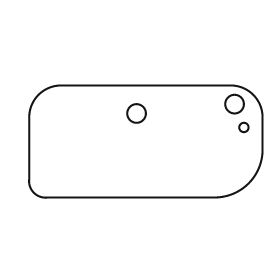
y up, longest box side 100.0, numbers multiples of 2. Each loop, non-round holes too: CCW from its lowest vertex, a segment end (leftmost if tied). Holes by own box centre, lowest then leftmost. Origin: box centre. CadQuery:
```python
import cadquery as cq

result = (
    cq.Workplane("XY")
    .moveTo(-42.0, -24.0)
    .lineTo(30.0, -24.0)
    .threePointArc((44.0, -18.0), (50.0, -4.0))
    .lineTo(50.0, 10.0)
    .threePointArc((46.0, 20.0), (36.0, 24.0))
    .lineTo(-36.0, 24.0)
    .threePointArc((-46.0, 20.0), (-50.0, 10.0))
    .lineTo(-50.0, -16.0)
    .threePointArc((-48.0, -22.0), (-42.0, -24.0))
    .close()
    .moveTo(42.0, 6.0)
    .circle(2.0)
    .moveTo(-4.0, 12.0)
    .circle(4.0)
    .moveTo(38.0, 16.0)
    .circle(4.0)
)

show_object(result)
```